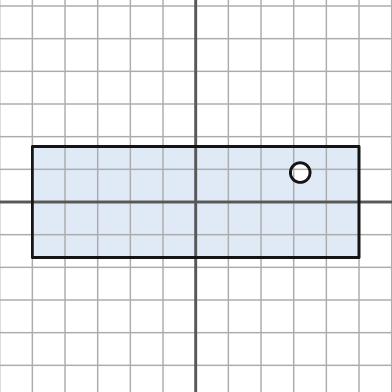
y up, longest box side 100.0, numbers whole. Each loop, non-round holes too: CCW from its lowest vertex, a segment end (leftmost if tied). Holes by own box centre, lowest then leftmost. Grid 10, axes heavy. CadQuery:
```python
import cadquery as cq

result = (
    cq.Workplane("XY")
    .moveTo(-50.0, -17.0)
    .lineTo(50.0, -17.0)
    .lineTo(50.0, 17.0)
    .lineTo(-50.0, 17.0)
    .close()
    .moveTo(32.0, 9.0)
    .circle(3.0)
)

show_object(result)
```